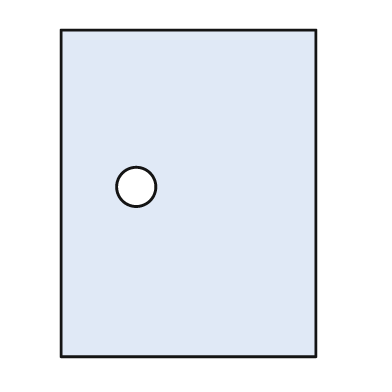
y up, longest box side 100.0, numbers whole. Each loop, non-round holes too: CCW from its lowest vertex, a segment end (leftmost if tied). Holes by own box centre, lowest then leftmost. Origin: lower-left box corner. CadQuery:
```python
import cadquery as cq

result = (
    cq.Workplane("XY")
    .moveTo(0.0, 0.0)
    .lineTo(78.0, 0.0)
    .lineTo(78.0, 100.0)
    .lineTo(0.0, 100.0)
    .close()
    .moveTo(23.0, 52.0)
    .circle(6.0)
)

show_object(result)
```